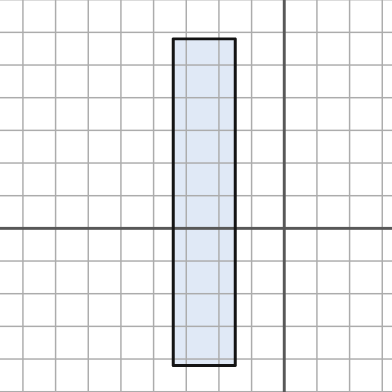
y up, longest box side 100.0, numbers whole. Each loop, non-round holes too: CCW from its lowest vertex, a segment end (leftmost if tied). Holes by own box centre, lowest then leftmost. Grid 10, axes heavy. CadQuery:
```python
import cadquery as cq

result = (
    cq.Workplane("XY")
    .moveTo(-34.0, -42.0)
    .lineTo(-15.0, -42.0)
    .lineTo(-15.0, 58.0)
    .lineTo(-34.0, 58.0)
    .close()
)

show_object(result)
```